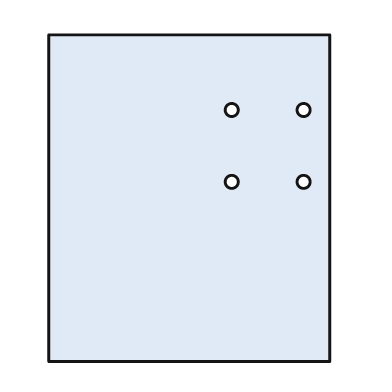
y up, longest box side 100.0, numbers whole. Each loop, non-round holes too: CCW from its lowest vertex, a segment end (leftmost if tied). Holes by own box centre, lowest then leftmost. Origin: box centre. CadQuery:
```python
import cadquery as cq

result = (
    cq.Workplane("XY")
    .moveTo(-43.0, -50.0)
    .lineTo(43.0, -50.0)
    .lineTo(43.0, 50.0)
    .lineTo(-43.0, 50.0)
    .close()
    .moveTo(13.0, 5.0)
    .circle(2.0)
    .moveTo(35.0, 5.0)
    .circle(2.0)
    .moveTo(13.0, 27.0)
    .circle(2.0)
    .moveTo(35.0, 27.0)
    .circle(2.0)
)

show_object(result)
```